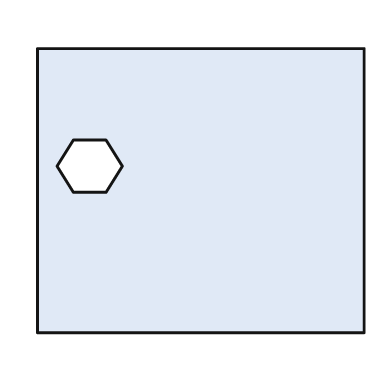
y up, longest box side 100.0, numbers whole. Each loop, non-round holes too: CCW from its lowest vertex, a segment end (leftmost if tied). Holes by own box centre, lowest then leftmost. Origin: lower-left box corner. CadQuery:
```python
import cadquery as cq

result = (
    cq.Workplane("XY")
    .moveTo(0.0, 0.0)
    .lineTo(100.0, 0.0)
    .lineTo(100.0, 87.0)
    .lineTo(0.0, 87.0)
    .close()
    .moveTo(11.0, 43.0)
    .lineTo(21.0, 43.0)
    .lineTo(26.0, 51.0)
    .lineTo(21.0, 59.0)
    .lineTo(11.0, 59.0)
    .lineTo(6.0, 51.0)
    .close()
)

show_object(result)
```